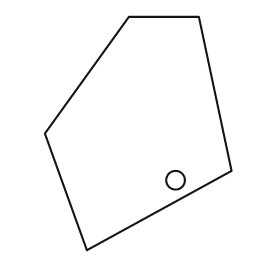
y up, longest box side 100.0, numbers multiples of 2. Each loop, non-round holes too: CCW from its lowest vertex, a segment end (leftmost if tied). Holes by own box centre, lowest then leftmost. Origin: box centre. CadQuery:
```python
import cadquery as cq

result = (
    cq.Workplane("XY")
    .moveTo(-22.0, -50.0)
    .lineTo(40.0, -16.0)
    .lineTo(26.0, 50.0)
    .lineTo(-4.0, 50.0)
    .lineTo(-40.0, 0.0)
    .close()
    .moveTo(16.0, -20.0)
    .circle(4.0)
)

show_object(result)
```